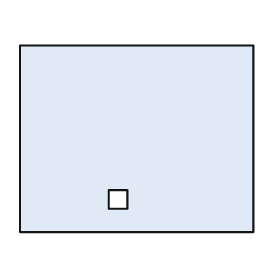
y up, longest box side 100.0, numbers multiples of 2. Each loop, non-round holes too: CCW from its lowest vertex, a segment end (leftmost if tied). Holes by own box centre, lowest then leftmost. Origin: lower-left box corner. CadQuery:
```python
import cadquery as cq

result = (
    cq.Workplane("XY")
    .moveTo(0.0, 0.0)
    .lineTo(100.0, 0.0)
    .lineTo(100.0, 80.0)
    .lineTo(0.0, 80.0)
    .close()
    .moveTo(38.0, 10.0)
    .lineTo(46.0, 10.0)
    .lineTo(46.0, 18.0)
    .lineTo(38.0, 18.0)
    .close()
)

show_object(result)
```